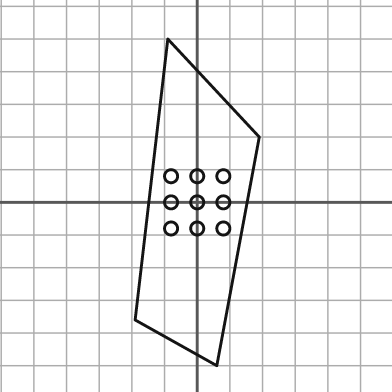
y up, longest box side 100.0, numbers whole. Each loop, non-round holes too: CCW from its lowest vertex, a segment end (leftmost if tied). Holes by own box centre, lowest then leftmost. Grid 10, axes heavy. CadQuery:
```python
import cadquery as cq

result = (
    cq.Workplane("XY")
    .moveTo(6.0, -50.0)
    .lineTo(19.0, 20.0)
    .lineTo(-9.0, 50.0)
    .lineTo(-19.0, -36.0)
    .close()
    .moveTo(-8.0, -8.0)
    .circle(2.0)
    .moveTo(0.0, -8.0)
    .circle(2.0)
    .moveTo(8.0, -8.0)
    .circle(2.0)
    .moveTo(-8.0, 0.0)
    .circle(2.0)
    .moveTo(0.0, 0.0)
    .circle(2.0)
    .moveTo(8.0, 0.0)
    .circle(2.0)
    .moveTo(-8.0, 8.0)
    .circle(2.0)
    .moveTo(0.0, 8.0)
    .circle(2.0)
    .moveTo(8.0, 8.0)
    .circle(2.0)
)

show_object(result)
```